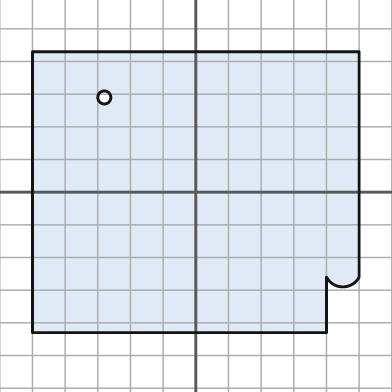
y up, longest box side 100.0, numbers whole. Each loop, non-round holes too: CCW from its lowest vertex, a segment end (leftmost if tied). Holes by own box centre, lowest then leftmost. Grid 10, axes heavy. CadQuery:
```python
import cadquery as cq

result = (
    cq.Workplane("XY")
    .moveTo(-50.0, -43.0)
    .lineTo(40.0, -43.0)
    .lineTo(40.0, -26.0)
    .threePointArc((45.0, -29.0), (50.0, -26.0))
    .lineTo(50.0, 43.0)
    .lineTo(-50.0, 43.0)
    .close()
    .moveTo(-28.0, 29.0)
    .circle(2.0)
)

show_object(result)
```